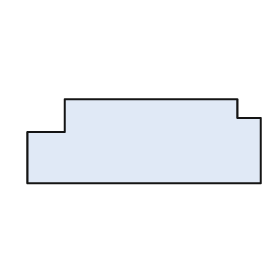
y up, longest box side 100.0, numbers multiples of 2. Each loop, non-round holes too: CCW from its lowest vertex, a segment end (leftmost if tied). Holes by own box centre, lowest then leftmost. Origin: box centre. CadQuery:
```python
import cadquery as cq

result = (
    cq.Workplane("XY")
    .moveTo(-50.0, -18.0)
    .lineTo(50.0, -18.0)
    .lineTo(50.0, 10.0)
    .lineTo(40.0, 10.0)
    .lineTo(40.0, 18.0)
    .lineTo(-34.0, 18.0)
    .lineTo(-34.0, 4.0)
    .lineTo(-50.0, 4.0)
    .close()
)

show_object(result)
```